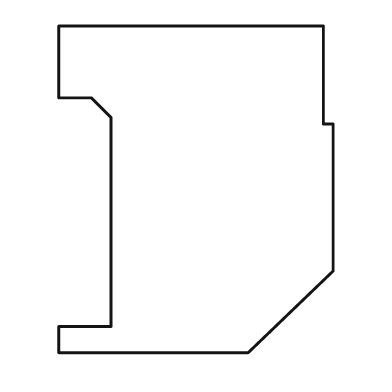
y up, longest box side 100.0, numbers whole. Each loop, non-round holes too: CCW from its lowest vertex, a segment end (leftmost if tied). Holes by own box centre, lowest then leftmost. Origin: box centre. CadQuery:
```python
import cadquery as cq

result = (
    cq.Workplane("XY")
    .moveTo(-42.0, -50.0)
    .lineTo(16.0, -50.0)
    .lineTo(42.0, -25.0)
    .lineTo(42.0, 20.0)
    .lineTo(39.0, 20.0)
    .lineTo(39.0, 50.0)
    .lineTo(-42.0, 50.0)
    .lineTo(-42.0, 28.0)
    .lineTo(-32.0, 28.0)
    .lineTo(-26.0, 22.0)
    .lineTo(-26.0, -42.0)
    .lineTo(-42.0, -42.0)
    .close()
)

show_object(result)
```